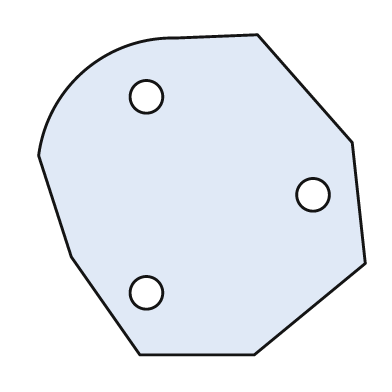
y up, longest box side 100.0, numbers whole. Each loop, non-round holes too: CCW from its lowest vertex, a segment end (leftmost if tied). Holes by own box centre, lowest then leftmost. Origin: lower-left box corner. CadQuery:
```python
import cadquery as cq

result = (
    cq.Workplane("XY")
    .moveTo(31.0, 0.0)
    .lineTo(66.0, 0.0)
    .lineTo(100.0, 28.0)
    .lineTo(96.0, 65.0)
    .lineTo(67.0, 98.0)
    .lineTo(42.0, 97.0)
    .threePointArc((14.0, 87.0), (0.0, 61.0))
    .lineTo(10.0, 30.0)
    .close()
    .moveTo(33.0, 19.0)
    .circle(5.0)
    .moveTo(84.0, 49.0)
    .circle(5.0)
    .moveTo(33.0, 79.0)
    .circle(5.0)
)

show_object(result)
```